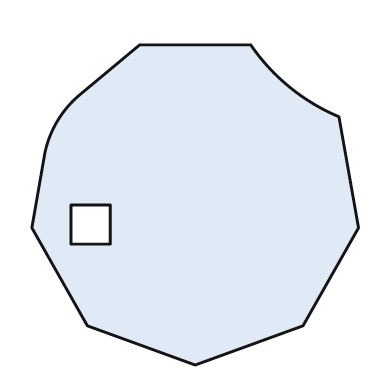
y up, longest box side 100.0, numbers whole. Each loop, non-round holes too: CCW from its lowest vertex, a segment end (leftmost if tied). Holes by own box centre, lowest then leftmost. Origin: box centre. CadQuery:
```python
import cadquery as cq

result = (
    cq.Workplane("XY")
    .moveTo(0.0, -49.0)
    .lineTo(33.0, -37.0)
    .lineTo(50.0, -7.0)
    .lineTo(44.0, 27.0)
    .threePointArc((29.0, 36.0), (17.0, 49.0))
    .lineTo(-17.0, 49.0)
    .lineTo(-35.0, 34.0)
    .threePointArc((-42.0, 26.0), (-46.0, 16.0))
    .lineTo(-50.0, -7.0)
    .lineTo(-33.0, -37.0)
    .close()
    .moveTo(-38.0, -12.0)
    .lineTo(-26.0, -12.0)
    .lineTo(-26.0, 0.0)
    .lineTo(-38.0, 0.0)
    .close()
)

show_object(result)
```